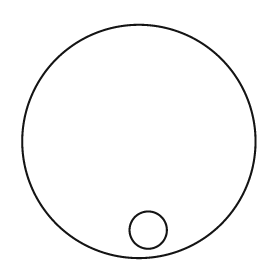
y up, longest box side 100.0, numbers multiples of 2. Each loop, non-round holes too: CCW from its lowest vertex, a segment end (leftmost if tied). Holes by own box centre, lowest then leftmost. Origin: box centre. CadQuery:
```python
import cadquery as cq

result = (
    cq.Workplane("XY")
    .moveTo(0.0, 0.0)
    .circle(50.0)
    .moveTo(4.0, -38.0)
    .circle(8.0)
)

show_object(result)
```